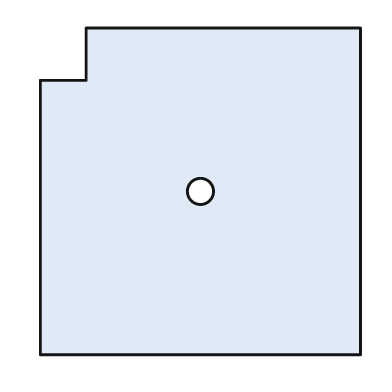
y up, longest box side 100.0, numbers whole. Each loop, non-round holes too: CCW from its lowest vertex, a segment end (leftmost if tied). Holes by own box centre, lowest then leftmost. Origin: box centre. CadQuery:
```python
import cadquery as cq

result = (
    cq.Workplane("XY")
    .moveTo(-49.0, -50.0)
    .lineTo(49.0, -50.0)
    .lineTo(49.0, 50.0)
    .lineTo(-35.0, 50.0)
    .lineTo(-35.0, 34.0)
    .lineTo(-49.0, 34.0)
    .close()
    .moveTo(0.0, 0.0)
    .circle(4.0)
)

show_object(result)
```